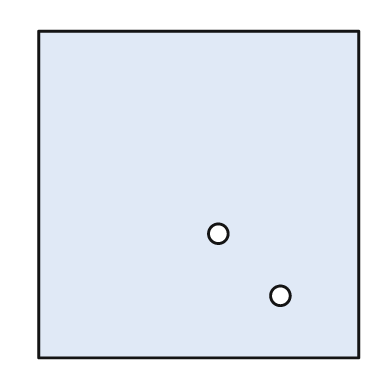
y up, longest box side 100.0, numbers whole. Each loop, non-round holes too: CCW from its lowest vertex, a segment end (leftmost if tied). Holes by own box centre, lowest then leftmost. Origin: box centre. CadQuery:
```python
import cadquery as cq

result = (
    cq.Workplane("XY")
    .moveTo(-49.0, -50.0)
    .lineTo(49.0, -50.0)
    .lineTo(49.0, 50.0)
    .lineTo(-49.0, 50.0)
    .close()
    .moveTo(25.0, -31.0)
    .circle(3.0)
    .moveTo(6.0, -12.0)
    .circle(3.0)
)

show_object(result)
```